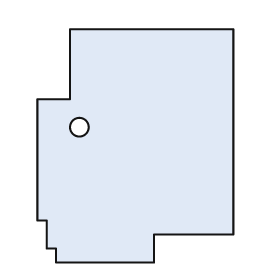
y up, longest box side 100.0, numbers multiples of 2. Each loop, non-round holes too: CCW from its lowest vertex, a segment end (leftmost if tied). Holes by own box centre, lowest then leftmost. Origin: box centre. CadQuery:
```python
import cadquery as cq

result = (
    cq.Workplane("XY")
    .moveTo(-34.0, -50.0)
    .lineTo(8.0, -50.0)
    .lineTo(8.0, -38.0)
    .lineTo(42.0, -38.0)
    .lineTo(42.0, 50.0)
    .lineTo(-28.0, 50.0)
    .lineTo(-28.0, 20.0)
    .lineTo(-42.0, 20.0)
    .lineTo(-42.0, -32.0)
    .lineTo(-38.0, -32.0)
    .lineTo(-38.0, -44.0)
    .lineTo(-34.0, -44.0)
    .close()
    .moveTo(-24.0, 8.0)
    .circle(4.0)
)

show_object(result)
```